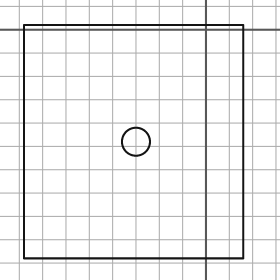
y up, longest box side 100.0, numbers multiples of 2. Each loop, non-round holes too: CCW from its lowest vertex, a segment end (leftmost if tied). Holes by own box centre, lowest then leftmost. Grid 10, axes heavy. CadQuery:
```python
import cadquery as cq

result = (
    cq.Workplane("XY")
    .moveTo(-78.0, -98.0)
    .lineTo(16.0, -98.0)
    .lineTo(16.0, 2.0)
    .lineTo(-78.0, 2.0)
    .close()
    .moveTo(-30.0, -48.0)
    .circle(6.0)
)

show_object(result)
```